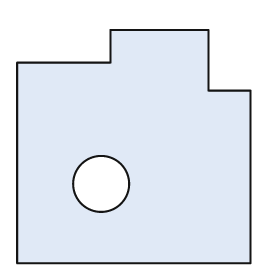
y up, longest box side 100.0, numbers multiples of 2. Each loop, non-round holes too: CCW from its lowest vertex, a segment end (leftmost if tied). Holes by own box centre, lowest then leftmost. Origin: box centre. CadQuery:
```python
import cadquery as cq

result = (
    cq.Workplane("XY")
    .moveTo(-50.0, -50.0)
    .lineTo(50.0, -50.0)
    .lineTo(50.0, 24.0)
    .lineTo(32.0, 24.0)
    .lineTo(32.0, 50.0)
    .lineTo(-10.0, 50.0)
    .lineTo(-10.0, 36.0)
    .lineTo(-50.0, 36.0)
    .close()
    .moveTo(-14.0, -16.0)
    .circle(12.0)
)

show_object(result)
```